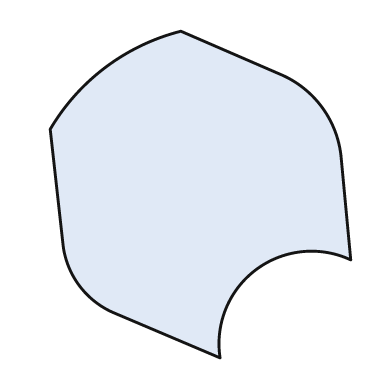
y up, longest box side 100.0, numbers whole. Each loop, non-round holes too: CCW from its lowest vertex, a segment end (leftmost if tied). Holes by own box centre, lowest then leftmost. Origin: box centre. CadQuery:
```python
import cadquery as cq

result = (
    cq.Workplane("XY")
    .moveTo(6.0, -50.0)
    .threePointArc((17.0, -23.0), (46.0, -20.0))
    .lineTo(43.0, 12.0)
    .threePointArc((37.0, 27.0), (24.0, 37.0))
    .lineTo(-6.0, 50.0)
    .threePointArc((-29.0, 39.0), (-46.0, 20.0))
    .lineTo(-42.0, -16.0)
    .threePointArc((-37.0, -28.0), (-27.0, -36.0))
    .close()
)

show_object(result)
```